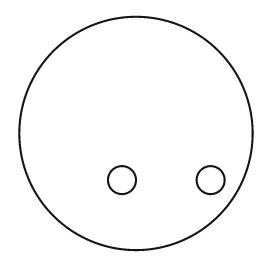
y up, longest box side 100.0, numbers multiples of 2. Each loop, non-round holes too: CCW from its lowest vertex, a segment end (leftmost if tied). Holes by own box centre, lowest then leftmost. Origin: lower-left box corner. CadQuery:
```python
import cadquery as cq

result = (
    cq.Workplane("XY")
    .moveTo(50.0, 50.0)
    .circle(50.0)
    .moveTo(44.0, 30.0)
    .circle(6.0)
    .moveTo(82.0, 30.0)
    .circle(6.0)
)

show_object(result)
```